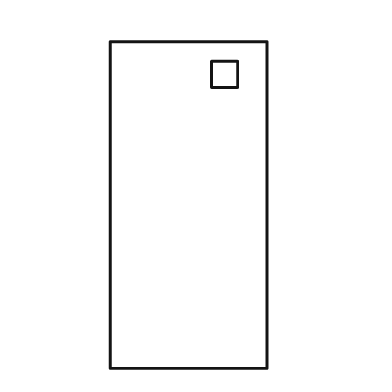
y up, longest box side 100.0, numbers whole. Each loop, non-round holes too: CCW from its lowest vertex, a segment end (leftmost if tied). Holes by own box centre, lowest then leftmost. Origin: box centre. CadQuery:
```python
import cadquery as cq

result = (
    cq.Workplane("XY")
    .moveTo(-24.0, -50.0)
    .lineTo(24.0, -50.0)
    .lineTo(24.0, 50.0)
    .lineTo(-24.0, 50.0)
    .close()
    .moveTo(7.0, 36.0)
    .lineTo(15.0, 36.0)
    .lineTo(15.0, 44.0)
    .lineTo(7.0, 44.0)
    .close()
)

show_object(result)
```